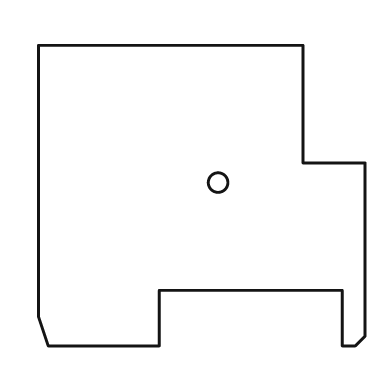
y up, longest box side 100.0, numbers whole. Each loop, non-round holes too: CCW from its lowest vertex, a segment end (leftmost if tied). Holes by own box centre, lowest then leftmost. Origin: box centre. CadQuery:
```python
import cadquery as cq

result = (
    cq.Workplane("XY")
    .moveTo(-47.0, -46.0)
    .lineTo(-13.0, -46.0)
    .lineTo(-13.0, -29.0)
    .lineTo(43.0, -29.0)
    .lineTo(43.0, -46.0)
    .lineTo(47.0, -46.0)
    .lineTo(50.0, -43.0)
    .lineTo(50.0, 10.0)
    .lineTo(31.0, 10.0)
    .lineTo(31.0, 46.0)
    .lineTo(-50.0, 46.0)
    .lineTo(-50.0, -37.0)
    .close()
    .moveTo(5.0, 4.0)
    .circle(3.0)
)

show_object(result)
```